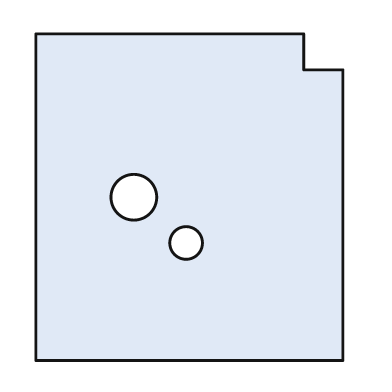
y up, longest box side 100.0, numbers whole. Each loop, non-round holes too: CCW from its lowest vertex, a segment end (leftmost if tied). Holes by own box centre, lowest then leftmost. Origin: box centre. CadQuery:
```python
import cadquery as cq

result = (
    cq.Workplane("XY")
    .moveTo(-47.0, -50.0)
    .lineTo(47.0, -50.0)
    .lineTo(47.0, 39.0)
    .lineTo(35.0, 39.0)
    .lineTo(35.0, 50.0)
    .lineTo(-47.0, 50.0)
    .close()
    .moveTo(-1.0, -14.0)
    .circle(5.0)
    .moveTo(-17.0, 0.0)
    .circle(7.0)
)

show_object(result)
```